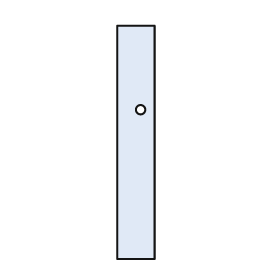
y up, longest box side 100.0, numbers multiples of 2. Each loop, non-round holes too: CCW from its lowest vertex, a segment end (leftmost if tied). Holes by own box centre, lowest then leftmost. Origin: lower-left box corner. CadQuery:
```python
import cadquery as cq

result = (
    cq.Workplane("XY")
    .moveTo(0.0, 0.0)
    .lineTo(16.0, 0.0)
    .lineTo(16.0, 100.0)
    .lineTo(0.0, 100.0)
    .close()
    .moveTo(10.0, 64.0)
    .circle(2.0)
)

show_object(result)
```